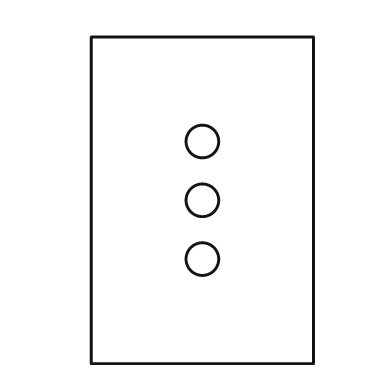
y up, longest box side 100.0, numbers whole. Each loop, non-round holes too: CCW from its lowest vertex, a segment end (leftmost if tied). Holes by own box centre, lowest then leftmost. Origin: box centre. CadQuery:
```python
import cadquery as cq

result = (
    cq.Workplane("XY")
    .moveTo(-34.0, -50.0)
    .lineTo(34.0, -50.0)
    .lineTo(34.0, 50.0)
    .lineTo(-34.0, 50.0)
    .close()
    .moveTo(0.0, -18.0)
    .circle(5.0)
    .moveTo(0.0, 0.0)
    .circle(5.0)
    .moveTo(0.0, 18.0)
    .circle(5.0)
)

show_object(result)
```